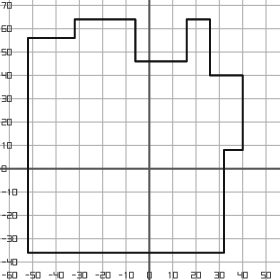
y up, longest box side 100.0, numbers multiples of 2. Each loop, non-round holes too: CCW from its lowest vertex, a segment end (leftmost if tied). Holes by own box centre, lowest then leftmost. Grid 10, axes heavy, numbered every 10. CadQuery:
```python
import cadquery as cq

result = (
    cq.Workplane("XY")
    .moveTo(-52.0, -36.0)
    .lineTo(32.0, -36.0)
    .lineTo(32.0, 8.0)
    .lineTo(40.0, 8.0)
    .lineTo(40.0, 40.0)
    .lineTo(26.0, 40.0)
    .lineTo(26.0, 64.0)
    .lineTo(16.0, 64.0)
    .lineTo(16.0, 46.0)
    .lineTo(-6.0, 46.0)
    .lineTo(-6.0, 64.0)
    .lineTo(-32.0, 64.0)
    .lineTo(-32.0, 56.0)
    .lineTo(-52.0, 56.0)
    .close()
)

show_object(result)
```